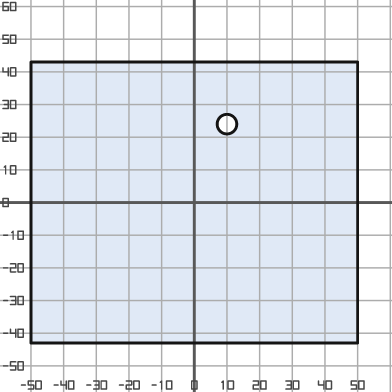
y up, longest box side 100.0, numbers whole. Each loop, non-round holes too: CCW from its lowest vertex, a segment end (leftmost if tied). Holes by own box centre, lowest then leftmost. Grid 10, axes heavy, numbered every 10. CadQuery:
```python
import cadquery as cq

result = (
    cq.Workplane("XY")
    .moveTo(-50.0, -43.0)
    .lineTo(50.0, -43.0)
    .lineTo(50.0, 43.0)
    .lineTo(-50.0, 43.0)
    .close()
    .moveTo(10.0, 24.0)
    .circle(3.0)
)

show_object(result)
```